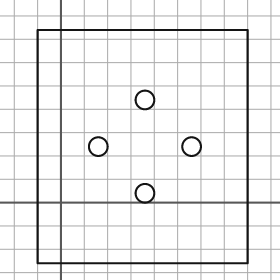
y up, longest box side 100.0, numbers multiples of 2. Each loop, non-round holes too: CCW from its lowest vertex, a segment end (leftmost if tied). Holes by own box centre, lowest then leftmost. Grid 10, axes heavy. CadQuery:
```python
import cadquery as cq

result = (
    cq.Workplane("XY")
    .moveTo(-10.0, -26.0)
    .lineTo(80.0, -26.0)
    .lineTo(80.0, 74.0)
    .lineTo(-10.0, 74.0)
    .close()
    .moveTo(36.0, 4.0)
    .circle(4.0)
    .moveTo(16.0, 24.0)
    .circle(4.0)
    .moveTo(56.0, 24.0)
    .circle(4.0)
    .moveTo(36.0, 44.0)
    .circle(4.0)
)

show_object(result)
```